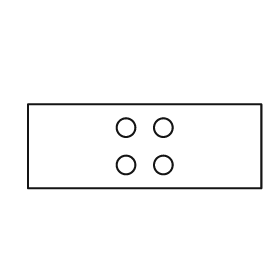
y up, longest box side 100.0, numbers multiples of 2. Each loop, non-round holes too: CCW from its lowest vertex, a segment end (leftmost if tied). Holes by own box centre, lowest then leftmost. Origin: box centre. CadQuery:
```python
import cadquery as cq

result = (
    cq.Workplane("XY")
    .moveTo(-50.0, -18.0)
    .lineTo(50.0, -18.0)
    .lineTo(50.0, 18.0)
    .lineTo(-50.0, 18.0)
    .close()
    .moveTo(-8.0, -8.0)
    .circle(4.0)
    .moveTo(8.0, -8.0)
    .circle(4.0)
    .moveTo(-8.0, 8.0)
    .circle(4.0)
    .moveTo(8.0, 8.0)
    .circle(4.0)
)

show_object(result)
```